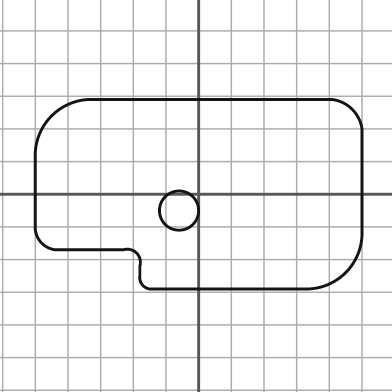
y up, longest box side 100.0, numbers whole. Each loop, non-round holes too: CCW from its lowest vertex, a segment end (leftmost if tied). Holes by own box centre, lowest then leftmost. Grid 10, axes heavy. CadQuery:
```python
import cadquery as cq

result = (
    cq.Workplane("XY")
    .moveTo(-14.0, -29.0)
    .lineTo(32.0, -29.0)
    .threePointArc((45.0, -24.0), (50.0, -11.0))
    .lineTo(50.0, 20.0)
    .threePointArc((47.0, 26.0), (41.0, 29.0))
    .lineTo(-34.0, 29.0)
    .threePointArc((-45.0, 24.0), (-50.0, 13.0))
    .lineTo(-50.0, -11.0)
    .threePointArc((-48.0, -15.0), (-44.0, -17.0))
    .lineTo(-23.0, -17.0)
    .threePointArc((-19.0, -18.0), (-18.0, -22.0))
    .lineTo(-18.0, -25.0)
    .threePointArc((-17.0, -28.0), (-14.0, -29.0))
    .close()
    .moveTo(-6.0, -5.0)
    .circle(6.0)
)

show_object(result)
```